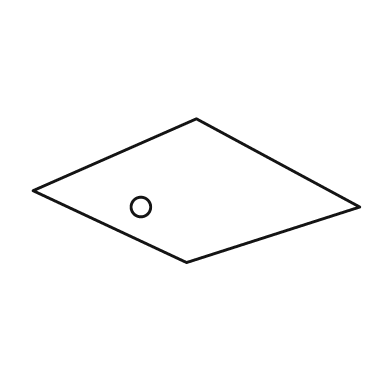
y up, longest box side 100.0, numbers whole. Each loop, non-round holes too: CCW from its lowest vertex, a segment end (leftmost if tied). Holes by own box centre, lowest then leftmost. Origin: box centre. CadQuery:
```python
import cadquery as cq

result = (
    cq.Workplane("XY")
    .moveTo(-3.0, -22.0)
    .lineTo(50.0, -5.0)
    .lineTo(0.0, 22.0)
    .lineTo(-50.0, 0.0)
    .close()
    .moveTo(-17.0, -5.0)
    .circle(3.0)
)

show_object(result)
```